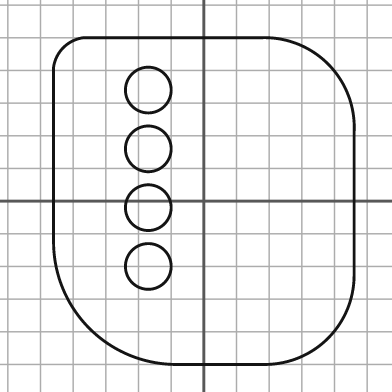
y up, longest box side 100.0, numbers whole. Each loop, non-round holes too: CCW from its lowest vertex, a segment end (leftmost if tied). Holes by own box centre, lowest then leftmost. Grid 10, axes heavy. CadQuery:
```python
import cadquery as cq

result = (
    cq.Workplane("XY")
    .moveTo(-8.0, -50.0)
    .lineTo(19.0, -50.0)
    .threePointArc((38.0, -42.0), (46.0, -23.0))
    .lineTo(46.0, 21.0)
    .threePointArc((38.0, 42.0), (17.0, 50.0))
    .lineTo(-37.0, 50.0)
    .threePointArc((-43.0, 47.0), (-46.0, 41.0))
    .lineTo(-46.0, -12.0)
    .threePointArc((-35.0, -39.0), (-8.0, -50.0))
    .close()
    .moveTo(-17.0, -20.0)
    .circle(7.0)
    .moveTo(-17.0, -2.0)
    .circle(7.0)
    .moveTo(-17.0, 16.0)
    .circle(7.0)
    .moveTo(-17.0, 34.0)
    .circle(7.0)
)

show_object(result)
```